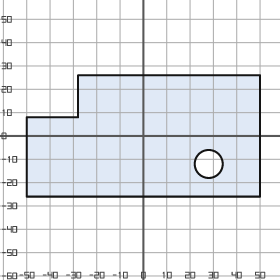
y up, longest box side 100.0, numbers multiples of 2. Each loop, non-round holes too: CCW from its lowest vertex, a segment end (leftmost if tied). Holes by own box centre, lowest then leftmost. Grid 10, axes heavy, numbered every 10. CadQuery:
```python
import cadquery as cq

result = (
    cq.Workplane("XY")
    .moveTo(-50.0, -26.0)
    .lineTo(50.0, -26.0)
    .lineTo(50.0, 26.0)
    .lineTo(-28.0, 26.0)
    .lineTo(-28.0, 8.0)
    .lineTo(-50.0, 8.0)
    .close()
    .moveTo(28.0, -12.0)
    .circle(6.0)
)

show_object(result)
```